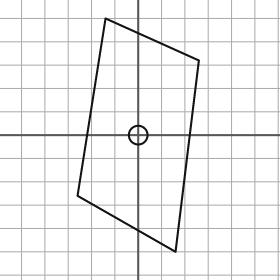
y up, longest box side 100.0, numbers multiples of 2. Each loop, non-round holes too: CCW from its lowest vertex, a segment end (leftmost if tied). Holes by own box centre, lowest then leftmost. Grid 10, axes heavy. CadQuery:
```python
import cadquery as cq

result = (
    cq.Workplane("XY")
    .moveTo(16.0, -50.0)
    .lineTo(26.0, 32.0)
    .lineTo(-14.0, 50.0)
    .lineTo(-26.0, -26.0)
    .close()
    .moveTo(0.0, 0.0)
    .circle(4.0)
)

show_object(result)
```